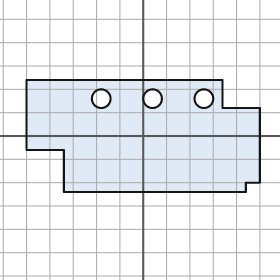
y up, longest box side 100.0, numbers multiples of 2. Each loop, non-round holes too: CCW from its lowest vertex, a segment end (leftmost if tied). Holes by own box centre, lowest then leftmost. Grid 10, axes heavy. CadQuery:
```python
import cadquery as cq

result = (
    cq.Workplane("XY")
    .moveTo(-34.0, -24.0)
    .lineTo(44.0, -24.0)
    .lineTo(44.0, -20.0)
    .lineTo(50.0, -20.0)
    .lineTo(50.0, 12.0)
    .lineTo(34.0, 12.0)
    .lineTo(34.0, 24.0)
    .lineTo(-50.0, 24.0)
    .lineTo(-50.0, -6.0)
    .lineTo(-34.0, -6.0)
    .close()
    .moveTo(-18.0, 16.0)
    .circle(4.0)
    .moveTo(4.0, 16.0)
    .circle(4.0)
    .moveTo(26.0, 16.0)
    .circle(4.0)
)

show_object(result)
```